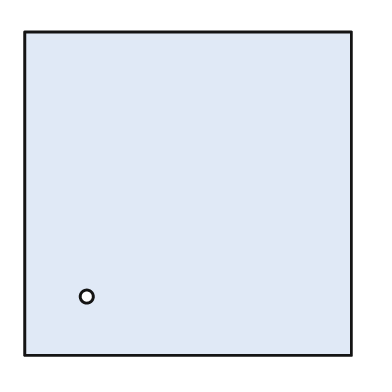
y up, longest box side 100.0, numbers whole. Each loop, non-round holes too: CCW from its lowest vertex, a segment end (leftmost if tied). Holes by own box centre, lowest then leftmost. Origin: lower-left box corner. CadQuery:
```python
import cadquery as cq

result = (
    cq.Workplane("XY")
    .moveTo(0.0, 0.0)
    .lineTo(100.0, 0.0)
    .lineTo(100.0, 99.0)
    .lineTo(0.0, 99.0)
    .close()
    .moveTo(19.0, 18.0)
    .circle(2.0)
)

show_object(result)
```